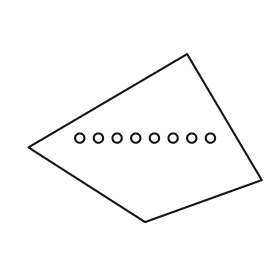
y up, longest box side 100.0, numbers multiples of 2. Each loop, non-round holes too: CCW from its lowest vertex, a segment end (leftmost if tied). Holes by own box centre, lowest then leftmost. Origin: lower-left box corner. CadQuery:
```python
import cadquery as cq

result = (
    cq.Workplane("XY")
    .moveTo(50.0, 0.0)
    .lineTo(100.0, 18.0)
    .lineTo(68.0, 72.0)
    .lineTo(0.0, 32.0)
    .close()
    .moveTo(22.0, 36.0)
    .circle(2.0)
    .moveTo(30.0, 36.0)
    .circle(2.0)
    .moveTo(38.0, 36.0)
    .circle(2.0)
    .moveTo(46.0, 36.0)
    .circle(2.0)
    .moveTo(54.0, 36.0)
    .circle(2.0)
    .moveTo(62.0, 36.0)
    .circle(2.0)
    .moveTo(70.0, 36.0)
    .circle(2.0)
    .moveTo(78.0, 36.0)
    .circle(2.0)
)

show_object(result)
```